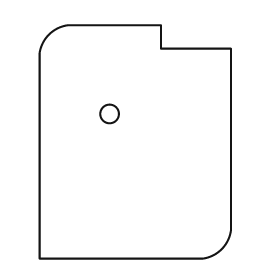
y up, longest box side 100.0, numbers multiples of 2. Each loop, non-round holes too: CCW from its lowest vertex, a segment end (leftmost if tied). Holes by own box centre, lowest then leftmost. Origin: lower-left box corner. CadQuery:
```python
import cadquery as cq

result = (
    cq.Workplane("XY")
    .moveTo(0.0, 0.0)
    .lineTo(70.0, 0.0)
    .threePointArc((78.0, 4.0), (82.0, 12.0))
    .lineTo(82.0, 90.0)
    .lineTo(52.0, 90.0)
    .lineTo(52.0, 100.0)
    .lineTo(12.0, 100.0)
    .threePointArc((4.0, 96.0), (0.0, 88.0))
    .close()
    .moveTo(30.0, 62.0)
    .circle(4.0)
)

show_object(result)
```